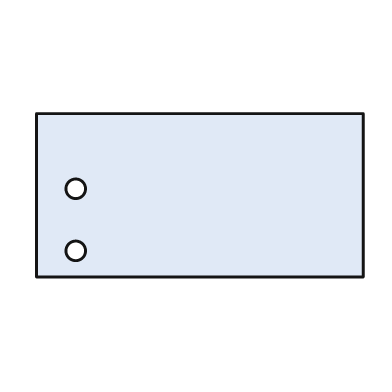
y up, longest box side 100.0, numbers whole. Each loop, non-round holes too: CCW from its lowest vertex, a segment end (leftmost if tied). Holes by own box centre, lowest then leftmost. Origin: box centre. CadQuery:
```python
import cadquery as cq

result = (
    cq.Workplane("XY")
    .moveTo(-50.0, -25.0)
    .lineTo(50.0, -25.0)
    .lineTo(50.0, 25.0)
    .lineTo(-50.0, 25.0)
    .close()
    .moveTo(-38.0, -17.0)
    .circle(3.0)
    .moveTo(-38.0, 2.0)
    .circle(3.0)
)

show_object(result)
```